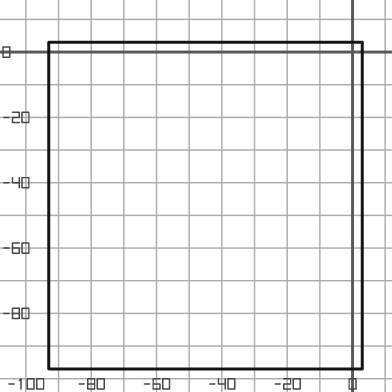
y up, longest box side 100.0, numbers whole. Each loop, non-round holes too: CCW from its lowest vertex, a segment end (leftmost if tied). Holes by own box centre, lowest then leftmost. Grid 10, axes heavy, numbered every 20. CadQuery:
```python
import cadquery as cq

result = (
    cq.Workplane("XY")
    .moveTo(-93.0, -97.0)
    .lineTo(3.0, -97.0)
    .lineTo(3.0, 3.0)
    .lineTo(-93.0, 3.0)
    .close()
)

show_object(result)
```